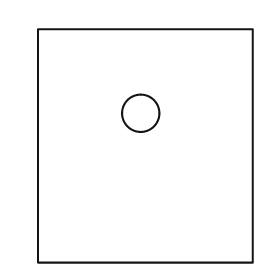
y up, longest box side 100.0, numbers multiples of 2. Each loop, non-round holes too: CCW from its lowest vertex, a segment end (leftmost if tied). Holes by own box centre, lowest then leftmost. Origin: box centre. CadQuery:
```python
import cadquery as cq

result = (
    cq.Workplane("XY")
    .moveTo(-46.0, -50.0)
    .lineTo(46.0, -50.0)
    .lineTo(46.0, 50.0)
    .lineTo(-46.0, 50.0)
    .close()
    .moveTo(-2.0, 14.0)
    .circle(8.0)
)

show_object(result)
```